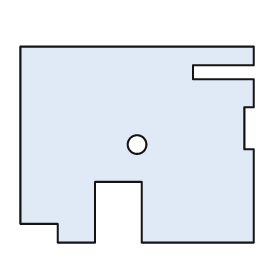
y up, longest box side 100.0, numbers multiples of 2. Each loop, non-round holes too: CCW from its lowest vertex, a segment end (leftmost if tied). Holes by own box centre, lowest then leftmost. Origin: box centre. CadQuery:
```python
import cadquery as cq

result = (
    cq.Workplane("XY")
    .moveTo(-34.0, -42.0)
    .lineTo(-18.0, -42.0)
    .lineTo(-18.0, -16.0)
    .lineTo(2.0, -16.0)
    .lineTo(2.0, -42.0)
    .lineTo(50.0, -42.0)
    .lineTo(50.0, -2.0)
    .lineTo(46.0, -2.0)
    .lineTo(46.0, 16.0)
    .lineTo(50.0, 16.0)
    .lineTo(50.0, 28.0)
    .lineTo(24.0, 28.0)
    .lineTo(24.0, 34.0)
    .lineTo(50.0, 34.0)
    .lineTo(50.0, 42.0)
    .lineTo(-50.0, 42.0)
    .lineTo(-50.0, -34.0)
    .lineTo(-34.0, -34.0)
    .close()
    .moveTo(0.0, 0.0)
    .circle(4.0)
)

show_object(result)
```